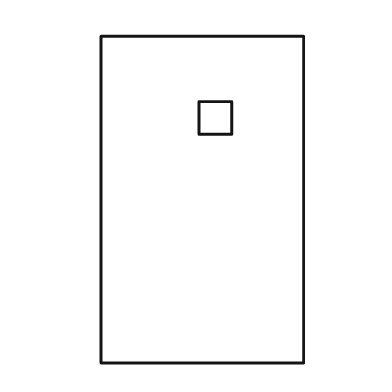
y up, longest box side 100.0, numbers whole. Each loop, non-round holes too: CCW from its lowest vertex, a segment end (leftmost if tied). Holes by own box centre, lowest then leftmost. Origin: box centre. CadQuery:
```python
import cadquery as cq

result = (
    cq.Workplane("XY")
    .moveTo(-31.0, -50.0)
    .lineTo(31.0, -50.0)
    .lineTo(31.0, 50.0)
    .lineTo(-31.0, 50.0)
    .close()
    .moveTo(-1.0, 20.0)
    .lineTo(9.0, 20.0)
    .lineTo(9.0, 30.0)
    .lineTo(-1.0, 30.0)
    .close()
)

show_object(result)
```